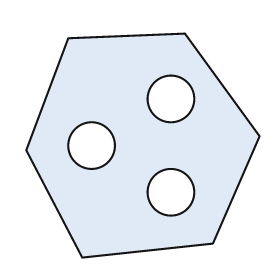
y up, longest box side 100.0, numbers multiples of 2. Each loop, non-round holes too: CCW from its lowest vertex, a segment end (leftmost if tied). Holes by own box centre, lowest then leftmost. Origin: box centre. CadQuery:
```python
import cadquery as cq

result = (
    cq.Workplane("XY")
    .moveTo(-26.0, -48.0)
    .lineTo(30.0, -42.0)
    .lineTo(50.0, 4.0)
    .lineTo(18.0, 48.0)
    .lineTo(-32.0, 46.0)
    .lineTo(-50.0, -2.0)
    .close()
    .moveTo(12.0, -20.0)
    .circle(10.0)
    .moveTo(-22.0, 0.0)
    .circle(10.0)
    .moveTo(12.0, 20.0)
    .circle(10.0)
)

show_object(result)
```